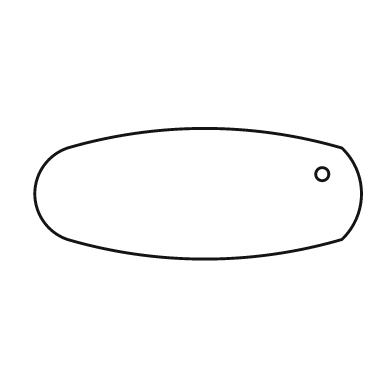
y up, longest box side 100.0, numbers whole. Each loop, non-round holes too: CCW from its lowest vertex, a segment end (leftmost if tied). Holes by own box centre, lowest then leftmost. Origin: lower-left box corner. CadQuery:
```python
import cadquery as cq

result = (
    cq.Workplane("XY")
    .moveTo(10.0, 6.0)
    .threePointArc((52.0, 0.0), (94.0, 6.0))
    .threePointArc((100.0, 20.0), (94.0, 34.0))
    .threePointArc((52.0, 40.0), (10.0, 34.0))
    .threePointArc((0.0, 20.0), (10.0, 6.0))
    .close()
    .moveTo(88.0, 26.0)
    .circle(2.0)
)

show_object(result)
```